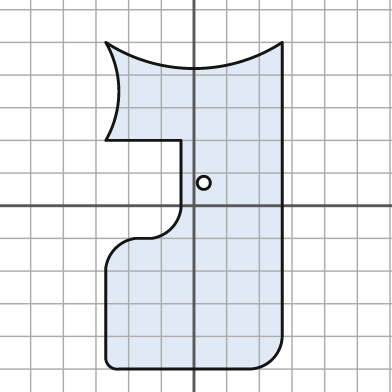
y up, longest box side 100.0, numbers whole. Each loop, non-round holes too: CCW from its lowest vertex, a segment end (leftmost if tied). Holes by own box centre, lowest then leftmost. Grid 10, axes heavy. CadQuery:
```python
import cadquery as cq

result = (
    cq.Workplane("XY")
    .moveTo(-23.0, -50.0)
    .lineTo(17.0, -50.0)
    .threePointArc((24.0, -47.0), (27.0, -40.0))
    .lineTo(27.0, 50.0)
    .threePointArc((0.0, 42.0), (-27.0, 50.0))
    .threePointArc((-23.0, 35.0), (-27.0, 20.0))
    .lineTo(-4.0, 20.0)
    .lineTo(-4.0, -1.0)
    .threePointArc((-7.0, -7.0), (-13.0, -10.0))
    .lineTo(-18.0, -10.0)
    .threePointArc((-24.0, -13.0), (-27.0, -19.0))
    .lineTo(-27.0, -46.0)
    .threePointArc((-26.0, -49.0), (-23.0, -50.0))
    .close()
    .moveTo(3.0, 7.0)
    .circle(2.0)
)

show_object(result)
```